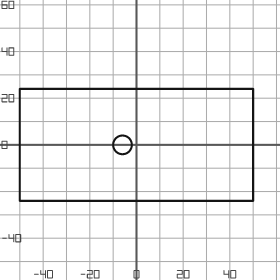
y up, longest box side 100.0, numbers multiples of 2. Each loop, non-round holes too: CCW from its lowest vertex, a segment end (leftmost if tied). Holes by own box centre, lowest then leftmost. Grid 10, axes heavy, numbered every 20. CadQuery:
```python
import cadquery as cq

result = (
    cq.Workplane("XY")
    .moveTo(-50.0, -24.0)
    .lineTo(50.0, -24.0)
    .lineTo(50.0, 24.0)
    .lineTo(-50.0, 24.0)
    .close()
    .moveTo(-6.0, 0.0)
    .circle(4.0)
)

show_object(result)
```